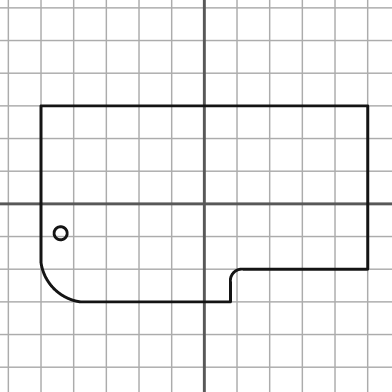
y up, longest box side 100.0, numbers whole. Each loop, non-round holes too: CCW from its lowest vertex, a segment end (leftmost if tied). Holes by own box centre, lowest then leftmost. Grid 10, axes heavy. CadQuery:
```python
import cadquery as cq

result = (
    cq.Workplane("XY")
    .moveTo(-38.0, -30.0)
    .lineTo(8.0, -30.0)
    .lineTo(8.0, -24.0)
    .threePointArc((9.0, -21.0), (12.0, -20.0))
    .lineTo(50.0, -20.0)
    .lineTo(50.0, 30.0)
    .lineTo(-50.0, 30.0)
    .lineTo(-50.0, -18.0)
    .threePointArc((-46.0, -26.0), (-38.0, -30.0))
    .close()
    .moveTo(-44.0, -9.0)
    .circle(2.0)
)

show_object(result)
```